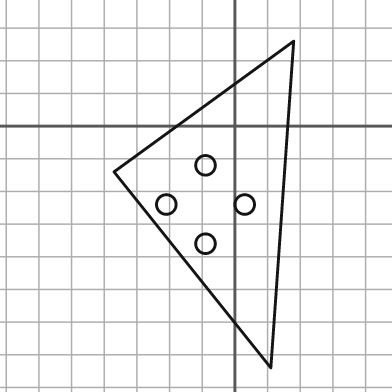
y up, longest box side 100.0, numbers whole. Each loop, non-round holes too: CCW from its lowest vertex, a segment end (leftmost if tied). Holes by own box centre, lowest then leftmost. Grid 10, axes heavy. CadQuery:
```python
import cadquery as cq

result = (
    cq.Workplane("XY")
    .moveTo(11.0, -74.0)
    .lineTo(18.0, 26.0)
    .lineTo(-37.0, -14.0)
    .close()
    .moveTo(-9.0, -36.0)
    .circle(3.0)
    .moveTo(-21.0, -24.0)
    .circle(3.0)
    .moveTo(3.0, -24.0)
    .circle(3.0)
    .moveTo(-9.0, -12.0)
    .circle(3.0)
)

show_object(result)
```